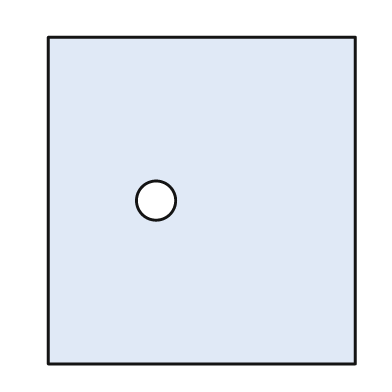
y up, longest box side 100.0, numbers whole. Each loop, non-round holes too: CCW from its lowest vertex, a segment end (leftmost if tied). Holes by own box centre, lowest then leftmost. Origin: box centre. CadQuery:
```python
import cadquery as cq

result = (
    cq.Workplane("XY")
    .moveTo(-47.0, -50.0)
    .lineTo(47.0, -50.0)
    .lineTo(47.0, 50.0)
    .lineTo(-47.0, 50.0)
    .close()
    .moveTo(-14.0, 0.0)
    .circle(6.0)
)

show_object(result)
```